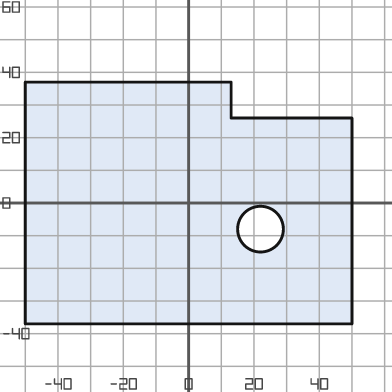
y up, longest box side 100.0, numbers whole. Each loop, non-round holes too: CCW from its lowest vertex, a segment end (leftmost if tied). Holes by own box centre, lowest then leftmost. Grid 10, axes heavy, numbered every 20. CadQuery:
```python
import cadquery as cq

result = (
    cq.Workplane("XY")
    .moveTo(-50.0, -37.0)
    .lineTo(50.0, -37.0)
    .lineTo(50.0, 26.0)
    .lineTo(13.0, 26.0)
    .lineTo(13.0, 37.0)
    .lineTo(-50.0, 37.0)
    .close()
    .moveTo(22.0, -8.0)
    .circle(7.0)
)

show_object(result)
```